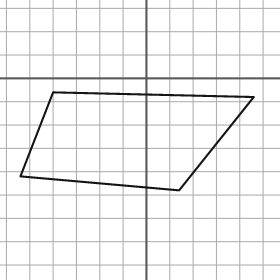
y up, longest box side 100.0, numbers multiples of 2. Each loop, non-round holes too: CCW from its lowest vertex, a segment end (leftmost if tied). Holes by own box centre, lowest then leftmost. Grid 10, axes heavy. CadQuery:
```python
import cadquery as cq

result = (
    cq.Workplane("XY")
    .moveTo(14.0, -48.0)
    .lineTo(46.0, -8.0)
    .lineTo(-40.0, -6.0)
    .lineTo(-54.0, -42.0)
    .close()
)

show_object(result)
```